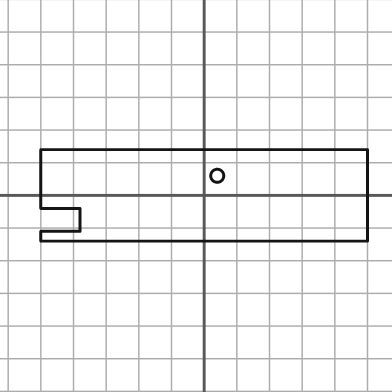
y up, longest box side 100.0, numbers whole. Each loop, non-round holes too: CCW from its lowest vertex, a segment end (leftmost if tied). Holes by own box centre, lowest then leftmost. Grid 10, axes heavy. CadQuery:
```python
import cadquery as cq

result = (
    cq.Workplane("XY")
    .moveTo(-50.0, -14.0)
    .lineTo(50.0, -14.0)
    .lineTo(50.0, 14.0)
    .lineTo(-50.0, 14.0)
    .lineTo(-50.0, -4.0)
    .lineTo(-38.0, -4.0)
    .lineTo(-38.0, -11.0)
    .lineTo(-50.0, -11.0)
    .close()
    .moveTo(4.0, 6.0)
    .circle(2.0)
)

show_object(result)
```